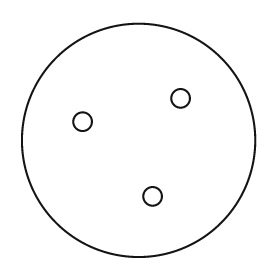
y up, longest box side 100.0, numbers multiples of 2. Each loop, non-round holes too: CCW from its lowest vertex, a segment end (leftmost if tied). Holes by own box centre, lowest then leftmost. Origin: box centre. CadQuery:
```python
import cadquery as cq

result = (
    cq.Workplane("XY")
    .moveTo(0.0, 0.0)
    .circle(50.0)
    .moveTo(6.0, -24.0)
    .circle(4.0)
    .moveTo(-24.0, 8.0)
    .circle(4.0)
    .moveTo(18.0, 18.0)
    .circle(4.0)
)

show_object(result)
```